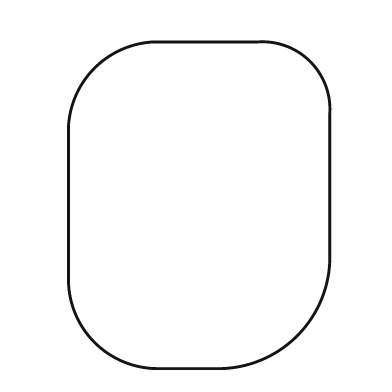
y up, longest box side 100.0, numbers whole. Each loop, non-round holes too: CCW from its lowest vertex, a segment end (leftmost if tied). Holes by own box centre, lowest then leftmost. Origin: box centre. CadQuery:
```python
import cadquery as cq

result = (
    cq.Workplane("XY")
    .moveTo(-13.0, -50.0)
    .lineTo(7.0, -50.0)
    .threePointArc((30.0, -40.0), (40.0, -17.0))
    .lineTo(40.0, 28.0)
    .threePointArc((34.0, 44.0), (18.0, 50.0))
    .lineTo(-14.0, 50.0)
    .threePointArc((-32.0, 42.0), (-40.0, 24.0))
    .lineTo(-40.0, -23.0)
    .threePointArc((-32.0, -42.0), (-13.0, -50.0))
    .close()
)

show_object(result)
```